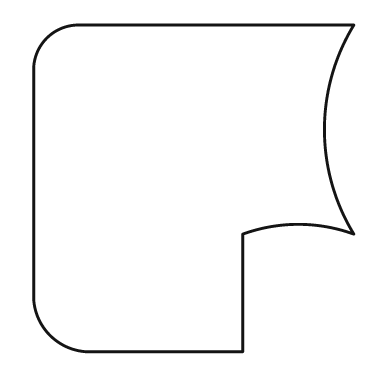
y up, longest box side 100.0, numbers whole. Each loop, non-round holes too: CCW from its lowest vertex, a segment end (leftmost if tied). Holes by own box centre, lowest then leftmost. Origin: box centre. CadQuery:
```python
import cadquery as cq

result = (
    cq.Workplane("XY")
    .moveTo(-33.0, -50.0)
    .lineTo(15.0, -50.0)
    .lineTo(15.0, -14.0)
    .threePointArc((32.0, -11.0), (49.0, -14.0))
    .threePointArc((40.0, 18.0), (49.0, 50.0))
    .lineTo(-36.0, 50.0)
    .threePointArc((-45.0, 46.0), (-49.0, 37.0))
    .lineTo(-49.0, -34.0)
    .threePointArc((-44.0, -45.0), (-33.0, -50.0))
    .close()
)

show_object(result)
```